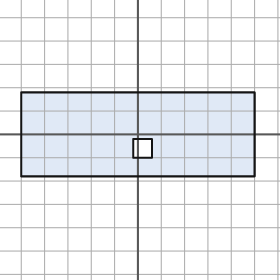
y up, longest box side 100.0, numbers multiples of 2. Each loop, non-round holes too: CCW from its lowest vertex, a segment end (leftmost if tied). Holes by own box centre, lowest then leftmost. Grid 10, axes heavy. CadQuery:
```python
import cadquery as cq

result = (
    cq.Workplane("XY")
    .moveTo(-50.0, -18.0)
    .lineTo(50.0, -18.0)
    .lineTo(50.0, 18.0)
    .lineTo(-50.0, 18.0)
    .close()
    .moveTo(-2.0, -10.0)
    .lineTo(6.0, -10.0)
    .lineTo(6.0, -2.0)
    .lineTo(-2.0, -2.0)
    .close()
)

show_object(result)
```